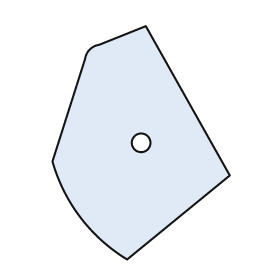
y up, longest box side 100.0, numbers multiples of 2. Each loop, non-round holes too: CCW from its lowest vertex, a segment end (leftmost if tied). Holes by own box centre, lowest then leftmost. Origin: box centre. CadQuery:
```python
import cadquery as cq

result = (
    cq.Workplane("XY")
    .moveTo(-6.0, -50.0)
    .lineTo(38.0, -14.0)
    .lineTo(2.0, 50.0)
    .lineTo(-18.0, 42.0)
    .threePointArc((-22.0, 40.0), (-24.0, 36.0))
    .lineTo(-38.0, -8.0)
    .threePointArc((-26.0, -32.0), (-6.0, -50.0))
    .close()
    .moveTo(0.0, 0.0)
    .circle(4.0)
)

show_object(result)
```